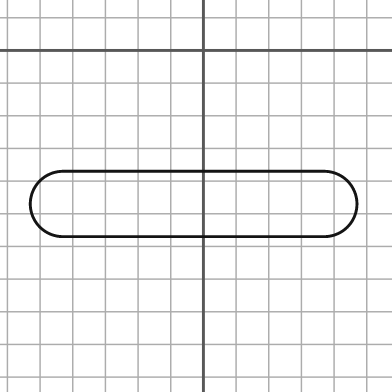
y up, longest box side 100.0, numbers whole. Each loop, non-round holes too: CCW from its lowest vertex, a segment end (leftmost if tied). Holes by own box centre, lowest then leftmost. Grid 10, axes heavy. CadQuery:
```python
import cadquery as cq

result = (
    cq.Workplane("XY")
    .moveTo(-43.0, -57.0)
    .lineTo(37.0, -57.0)
    .threePointArc((47.0, -47.0), (37.0, -37.0))
    .lineTo(-43.0, -37.0)
    .threePointArc((-53.0, -47.0), (-43.0, -57.0))
    .close()
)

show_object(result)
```